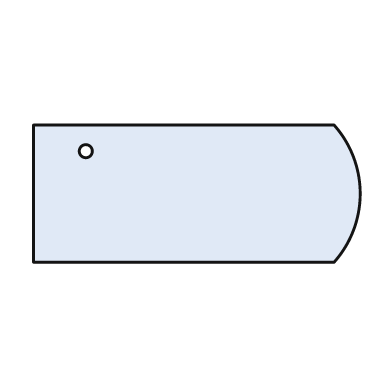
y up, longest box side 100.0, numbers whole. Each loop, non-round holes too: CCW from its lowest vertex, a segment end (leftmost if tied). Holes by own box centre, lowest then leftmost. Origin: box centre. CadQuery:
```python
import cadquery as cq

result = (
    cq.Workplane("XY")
    .moveTo(-50.0, -21.0)
    .lineTo(42.0, -21.0)
    .threePointArc((50.0, 0.0), (42.0, 21.0))
    .lineTo(-50.0, 21.0)
    .close()
    .moveTo(-34.0, 13.0)
    .circle(2.0)
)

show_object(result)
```